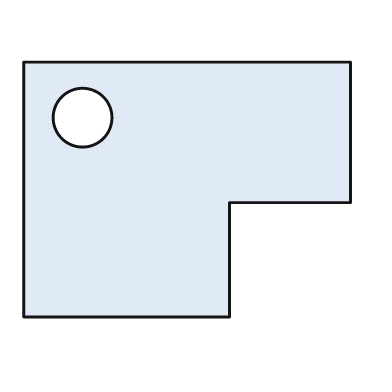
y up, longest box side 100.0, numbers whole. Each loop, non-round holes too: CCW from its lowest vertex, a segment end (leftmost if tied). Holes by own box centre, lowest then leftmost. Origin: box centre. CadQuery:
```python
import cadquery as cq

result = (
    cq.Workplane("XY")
    .moveTo(-50.0, -39.0)
    .lineTo(13.0, -39.0)
    .lineTo(13.0, -4.0)
    .lineTo(50.0, -4.0)
    .lineTo(50.0, 39.0)
    .lineTo(-50.0, 39.0)
    .close()
    .moveTo(-32.0, 22.0)
    .circle(9.0)
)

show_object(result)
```